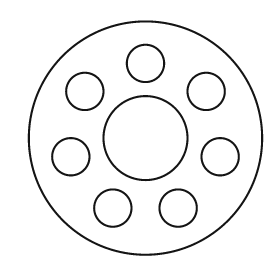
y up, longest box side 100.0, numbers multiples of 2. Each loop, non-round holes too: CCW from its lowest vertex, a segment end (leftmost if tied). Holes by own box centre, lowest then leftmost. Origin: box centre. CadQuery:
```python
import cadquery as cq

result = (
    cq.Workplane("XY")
    .moveTo(0.0, 0.0)
    .circle(50.0)
    .moveTo(-14.0, -30.0)
    .circle(8.0)
    .moveTo(14.0, -30.0)
    .circle(8.0)
    .moveTo(-32.0, -8.0)
    .circle(8.0)
    .moveTo(32.0, -8.0)
    .circle(8.0)
    .moveTo(0.0, 0.0)
    .circle(18.0)
    .moveTo(-26.0, 20.0)
    .circle(8.0)
    .moveTo(26.0, 20.0)
    .circle(8.0)
    .moveTo(0.0, 32.0)
    .circle(8.0)
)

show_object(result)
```